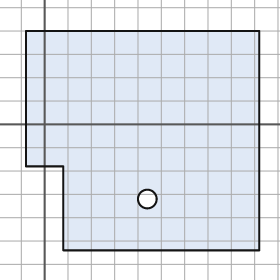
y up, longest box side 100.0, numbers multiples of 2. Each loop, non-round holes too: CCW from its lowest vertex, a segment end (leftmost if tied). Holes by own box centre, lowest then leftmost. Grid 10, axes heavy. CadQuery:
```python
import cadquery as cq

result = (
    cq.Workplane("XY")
    .moveTo(8.0, -54.0)
    .lineTo(92.0, -54.0)
    .lineTo(92.0, 40.0)
    .lineTo(-8.0, 40.0)
    .lineTo(-8.0, -18.0)
    .lineTo(8.0, -18.0)
    .close()
    .moveTo(44.0, -32.0)
    .circle(4.0)
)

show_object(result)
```